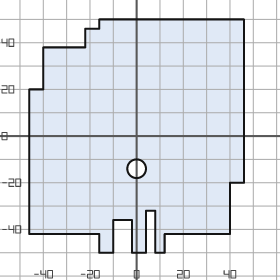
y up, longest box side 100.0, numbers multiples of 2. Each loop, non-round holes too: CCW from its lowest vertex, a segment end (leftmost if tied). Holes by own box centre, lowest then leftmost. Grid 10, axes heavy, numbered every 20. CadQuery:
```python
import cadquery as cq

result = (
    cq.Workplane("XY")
    .moveTo(-16.0, -50.0)
    .lineTo(-10.0, -50.0)
    .lineTo(-10.0, -36.0)
    .lineTo(-2.0, -36.0)
    .lineTo(-2.0, -50.0)
    .lineTo(4.0, -50.0)
    .lineTo(4.0, -32.0)
    .lineTo(8.0, -32.0)
    .lineTo(8.0, -50.0)
    .lineTo(12.0, -50.0)
    .lineTo(12.0, -42.0)
    .lineTo(40.0, -42.0)
    .lineTo(40.0, -20.0)
    .lineTo(46.0, -20.0)
    .lineTo(46.0, 50.0)
    .lineTo(-16.0, 50.0)
    .lineTo(-16.0, 46.0)
    .lineTo(-22.0, 46.0)
    .lineTo(-22.0, 38.0)
    .lineTo(-40.0, 38.0)
    .lineTo(-40.0, 20.0)
    .lineTo(-46.0, 20.0)
    .lineTo(-46.0, -42.0)
    .lineTo(-16.0, -42.0)
    .close()
    .moveTo(0.0, -14.0)
    .circle(4.0)
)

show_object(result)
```